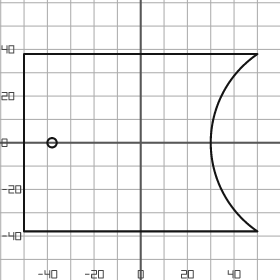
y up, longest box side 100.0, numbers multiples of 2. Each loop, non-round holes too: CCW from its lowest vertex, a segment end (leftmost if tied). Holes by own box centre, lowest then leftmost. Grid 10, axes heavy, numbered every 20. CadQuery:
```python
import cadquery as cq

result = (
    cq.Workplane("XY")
    .moveTo(-50.0, -38.0)
    .lineTo(50.0, -38.0)
    .threePointArc((30.0, 0.0), (50.0, 38.0))
    .lineTo(-50.0, 38.0)
    .close()
    .moveTo(-38.0, 0.0)
    .circle(2.0)
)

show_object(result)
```